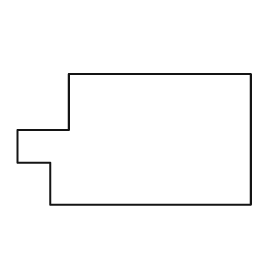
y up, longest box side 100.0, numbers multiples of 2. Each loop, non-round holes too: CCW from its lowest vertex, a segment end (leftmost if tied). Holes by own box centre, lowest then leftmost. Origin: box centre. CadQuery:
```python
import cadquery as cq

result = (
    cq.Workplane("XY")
    .moveTo(-36.0, -28.0)
    .lineTo(50.0, -28.0)
    .lineTo(50.0, 28.0)
    .lineTo(-28.0, 28.0)
    .lineTo(-28.0, 4.0)
    .lineTo(-50.0, 4.0)
    .lineTo(-50.0, -10.0)
    .lineTo(-36.0, -10.0)
    .close()
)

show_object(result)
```